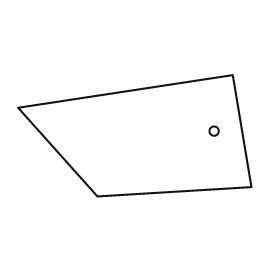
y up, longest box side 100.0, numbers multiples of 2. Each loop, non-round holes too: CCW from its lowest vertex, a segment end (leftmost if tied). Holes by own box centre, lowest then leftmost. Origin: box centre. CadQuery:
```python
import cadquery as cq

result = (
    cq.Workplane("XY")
    .moveTo(-16.0, -26.0)
    .lineTo(50.0, -22.0)
    .lineTo(42.0, 26.0)
    .lineTo(-50.0, 12.0)
    .close()
    .moveTo(34.0, 2.0)
    .circle(2.0)
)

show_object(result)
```